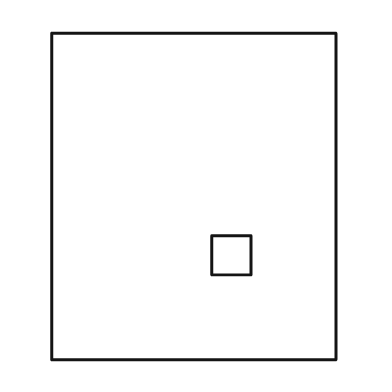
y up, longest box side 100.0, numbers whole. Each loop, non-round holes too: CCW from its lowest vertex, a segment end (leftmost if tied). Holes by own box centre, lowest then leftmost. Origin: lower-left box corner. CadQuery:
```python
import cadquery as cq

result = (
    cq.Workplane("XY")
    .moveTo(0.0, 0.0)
    .lineTo(87.0, 0.0)
    .lineTo(87.0, 100.0)
    .lineTo(0.0, 100.0)
    .close()
    .moveTo(49.0, 26.0)
    .lineTo(61.0, 26.0)
    .lineTo(61.0, 38.0)
    .lineTo(49.0, 38.0)
    .close()
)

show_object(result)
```